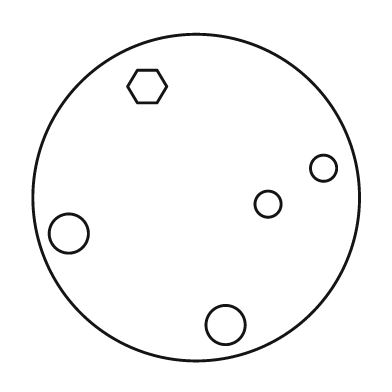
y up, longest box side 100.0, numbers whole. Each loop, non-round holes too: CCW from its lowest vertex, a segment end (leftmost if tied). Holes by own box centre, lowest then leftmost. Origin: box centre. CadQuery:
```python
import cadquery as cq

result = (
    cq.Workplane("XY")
    .moveTo(0.0, 0.0)
    .circle(50.0)
    .moveTo(9.0, -39.0)
    .circle(6.0)
    .moveTo(-39.0, -11.0)
    .circle(6.0)
    .moveTo(22.0, -2.0)
    .circle(4.0)
    .moveTo(39.0, 9.0)
    .circle(4.0)
    .moveTo(-18.0, 29.0)
    .lineTo(-12.0, 29.0)
    .lineTo(-9.0, 34.0)
    .lineTo(-12.0, 39.0)
    .lineTo(-18.0, 39.0)
    .lineTo(-21.0, 34.0)
    .close()
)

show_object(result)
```